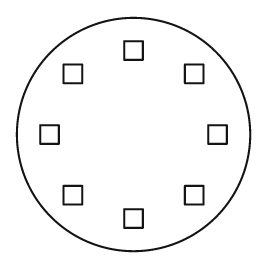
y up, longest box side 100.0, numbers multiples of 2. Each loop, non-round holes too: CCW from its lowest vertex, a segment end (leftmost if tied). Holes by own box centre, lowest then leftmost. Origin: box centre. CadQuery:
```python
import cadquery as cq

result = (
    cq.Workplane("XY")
    .moveTo(0.0, 0.0)
    .circle(50.0)
    .moveTo(-4.0, -40.0)
    .lineTo(4.0, -40.0)
    .lineTo(4.0, -32.0)
    .lineTo(-4.0, -32.0)
    .close()
    .moveTo(-30.0, -30.0)
    .lineTo(-22.0, -30.0)
    .lineTo(-22.0, -22.0)
    .lineTo(-30.0, -22.0)
    .close()
    .moveTo(22.0, -30.0)
    .lineTo(30.0, -30.0)
    .lineTo(30.0, -22.0)
    .lineTo(22.0, -22.0)
    .close()
    .moveTo(-40.0, -4.0)
    .lineTo(-32.0, -4.0)
    .lineTo(-32.0, 4.0)
    .lineTo(-40.0, 4.0)
    .close()
    .moveTo(32.0, -4.0)
    .lineTo(40.0, -4.0)
    .lineTo(40.0, 4.0)
    .lineTo(32.0, 4.0)
    .close()
    .moveTo(-30.0, 22.0)
    .lineTo(-22.0, 22.0)
    .lineTo(-22.0, 30.0)
    .lineTo(-30.0, 30.0)
    .close()
    .moveTo(22.0, 22.0)
    .lineTo(30.0, 22.0)
    .lineTo(30.0, 30.0)
    .lineTo(22.0, 30.0)
    .close()
    .moveTo(-4.0, 32.0)
    .lineTo(4.0, 32.0)
    .lineTo(4.0, 40.0)
    .lineTo(-4.0, 40.0)
    .close()
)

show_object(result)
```